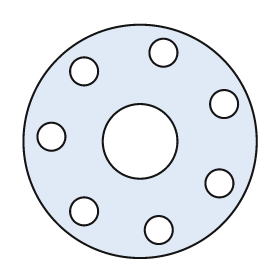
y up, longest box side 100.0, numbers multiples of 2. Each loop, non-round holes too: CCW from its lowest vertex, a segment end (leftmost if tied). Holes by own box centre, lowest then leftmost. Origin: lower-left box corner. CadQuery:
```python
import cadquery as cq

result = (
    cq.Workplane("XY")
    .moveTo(50.0, 50.0)
    .circle(50.0)
    .moveTo(58.0, 12.0)
    .circle(6.0)
    .moveTo(26.0, 20.0)
    .circle(6.0)
    .moveTo(84.0, 32.0)
    .circle(6.0)
    .moveTo(50.0, 50.0)
    .circle(16.0)
    .moveTo(12.0, 52.0)
    .circle(6.0)
    .moveTo(86.0, 66.0)
    .circle(6.0)
    .moveTo(26.0, 80.0)
    .circle(6.0)
    .moveTo(60.0, 88.0)
    .circle(6.0)
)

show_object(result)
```